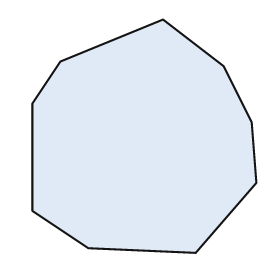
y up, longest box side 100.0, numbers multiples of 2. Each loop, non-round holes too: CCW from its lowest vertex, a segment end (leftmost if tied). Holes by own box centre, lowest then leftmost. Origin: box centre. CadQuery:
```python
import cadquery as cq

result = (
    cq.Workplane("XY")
    .moveTo(22.0, -50.0)
    .lineTo(48.0, -20.0)
    .lineTo(46.0, 6.0)
    .lineTo(34.0, 30.0)
    .lineTo(8.0, 50.0)
    .lineTo(-36.0, 32.0)
    .lineTo(-48.0, 14.0)
    .lineTo(-48.0, -32.0)
    .lineTo(-24.0, -48.0)
    .close()
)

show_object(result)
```